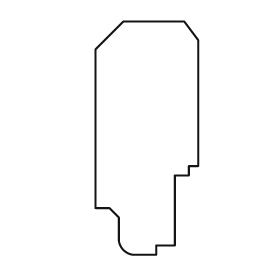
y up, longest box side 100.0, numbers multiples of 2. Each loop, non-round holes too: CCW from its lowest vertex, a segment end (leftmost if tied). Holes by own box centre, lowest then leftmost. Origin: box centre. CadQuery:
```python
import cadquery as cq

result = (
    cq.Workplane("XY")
    .moveTo(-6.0, -50.0)
    .lineTo(4.0, -50.0)
    .lineTo(4.0, -46.0)
    .lineTo(12.0, -46.0)
    .lineTo(12.0, -16.0)
    .lineTo(18.0, -16.0)
    .lineTo(18.0, -12.0)
    .lineTo(22.0, -12.0)
    .lineTo(22.0, 42.0)
    .lineTo(16.0, 50.0)
    .lineTo(-10.0, 50.0)
    .lineTo(-22.0, 38.0)
    .lineTo(-22.0, -30.0)
    .lineTo(-16.0, -30.0)
    .lineTo(-12.0, -34.0)
    .lineTo(-12.0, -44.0)
    .threePointArc((-10.0, -48.0), (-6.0, -50.0))
    .close()
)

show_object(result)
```